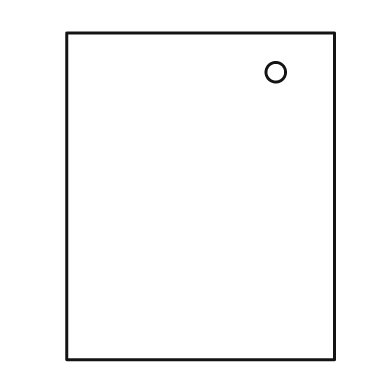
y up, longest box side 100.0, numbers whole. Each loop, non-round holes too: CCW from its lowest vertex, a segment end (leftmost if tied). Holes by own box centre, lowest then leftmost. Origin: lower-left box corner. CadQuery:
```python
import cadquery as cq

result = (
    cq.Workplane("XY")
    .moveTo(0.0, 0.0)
    .lineTo(82.0, 0.0)
    .lineTo(82.0, 100.0)
    .lineTo(0.0, 100.0)
    .close()
    .moveTo(64.0, 88.0)
    .circle(3.0)
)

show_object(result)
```